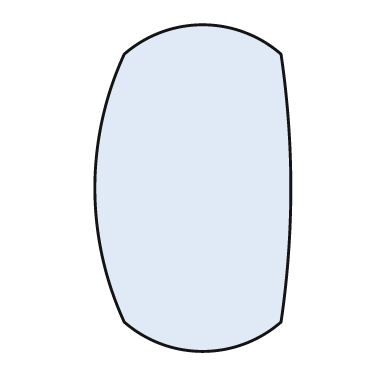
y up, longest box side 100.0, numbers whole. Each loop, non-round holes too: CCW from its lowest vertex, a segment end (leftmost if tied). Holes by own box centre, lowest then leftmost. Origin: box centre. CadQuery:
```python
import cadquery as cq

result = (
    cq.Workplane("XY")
    .moveTo(-21.0, -41.0)
    .threePointArc((3.0, -50.0), (27.0, -41.0))
    .threePointArc((30.0, 0.0), (27.0, 41.0))
    .threePointArc((3.0, 50.0), (-21.0, 41.0))
    .threePointArc((-30.0, 0.0), (-21.0, -41.0))
    .close()
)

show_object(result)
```